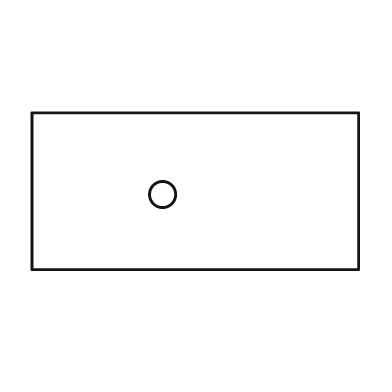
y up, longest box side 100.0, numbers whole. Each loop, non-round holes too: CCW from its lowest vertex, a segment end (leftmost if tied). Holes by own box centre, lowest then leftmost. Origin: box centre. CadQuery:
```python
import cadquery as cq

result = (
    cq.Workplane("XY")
    .moveTo(-50.0, -24.0)
    .lineTo(50.0, -24.0)
    .lineTo(50.0, 24.0)
    .lineTo(-50.0, 24.0)
    .close()
    .moveTo(-10.0, -1.0)
    .circle(4.0)
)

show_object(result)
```